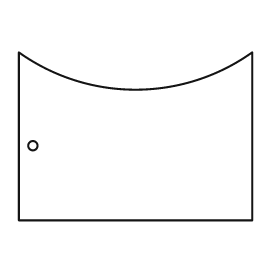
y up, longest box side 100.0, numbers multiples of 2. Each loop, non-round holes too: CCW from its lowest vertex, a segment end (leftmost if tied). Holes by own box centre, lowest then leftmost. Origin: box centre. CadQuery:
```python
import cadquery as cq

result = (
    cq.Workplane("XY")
    .moveTo(-50.0, -36.0)
    .lineTo(50.0, -36.0)
    .lineTo(50.0, 36.0)
    .threePointArc((0.0, 20.0), (-50.0, 36.0))
    .close()
    .moveTo(-44.0, -4.0)
    .circle(2.0)
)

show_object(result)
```